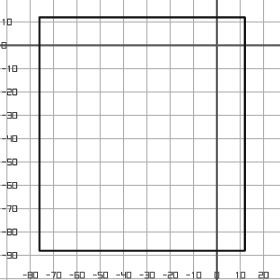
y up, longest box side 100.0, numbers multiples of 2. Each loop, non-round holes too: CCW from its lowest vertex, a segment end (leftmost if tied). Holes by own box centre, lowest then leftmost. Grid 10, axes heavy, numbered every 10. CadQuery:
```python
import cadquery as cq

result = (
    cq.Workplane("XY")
    .moveTo(-76.0, -88.0)
    .lineTo(12.0, -88.0)
    .lineTo(12.0, 12.0)
    .lineTo(-76.0, 12.0)
    .close()
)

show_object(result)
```